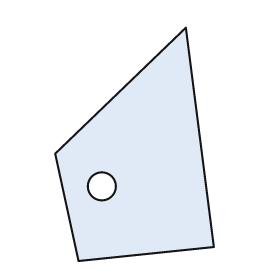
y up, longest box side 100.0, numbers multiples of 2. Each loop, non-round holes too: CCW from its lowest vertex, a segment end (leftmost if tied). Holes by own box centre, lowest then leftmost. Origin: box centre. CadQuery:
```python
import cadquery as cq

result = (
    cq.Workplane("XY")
    .moveTo(-24.0, -50.0)
    .lineTo(34.0, -44.0)
    .lineTo(22.0, 50.0)
    .lineTo(-34.0, -4.0)
    .close()
    .moveTo(-14.0, -18.0)
    .circle(6.0)
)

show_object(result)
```